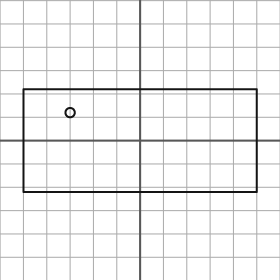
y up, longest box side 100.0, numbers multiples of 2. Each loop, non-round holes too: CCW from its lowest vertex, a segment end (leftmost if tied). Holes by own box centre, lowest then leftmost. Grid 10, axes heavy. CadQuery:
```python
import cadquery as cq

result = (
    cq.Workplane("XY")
    .moveTo(-50.0, -22.0)
    .lineTo(50.0, -22.0)
    .lineTo(50.0, 22.0)
    .lineTo(-50.0, 22.0)
    .close()
    .moveTo(-30.0, 12.0)
    .circle(2.0)
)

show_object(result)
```